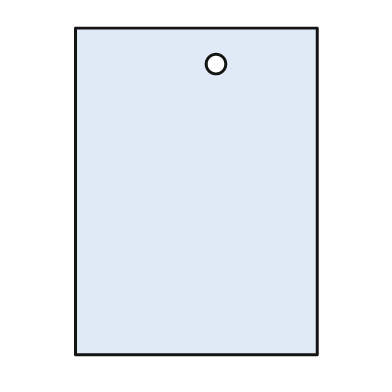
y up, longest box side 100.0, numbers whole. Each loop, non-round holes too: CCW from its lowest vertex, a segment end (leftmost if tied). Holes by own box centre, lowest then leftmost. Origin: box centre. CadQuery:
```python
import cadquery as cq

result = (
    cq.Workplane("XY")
    .moveTo(-37.0, -50.0)
    .lineTo(37.0, -50.0)
    .lineTo(37.0, 50.0)
    .lineTo(-37.0, 50.0)
    .close()
    .moveTo(6.0, 39.0)
    .circle(3.0)
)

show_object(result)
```